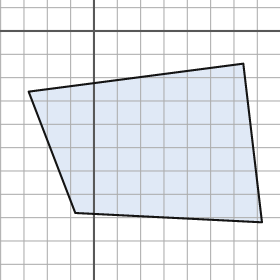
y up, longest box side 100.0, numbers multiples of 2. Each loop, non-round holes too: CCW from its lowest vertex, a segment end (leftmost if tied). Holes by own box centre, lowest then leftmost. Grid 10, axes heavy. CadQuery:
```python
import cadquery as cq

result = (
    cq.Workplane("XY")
    .moveTo(72.0, -82.0)
    .lineTo(64.0, -14.0)
    .lineTo(-28.0, -26.0)
    .lineTo(-8.0, -78.0)
    .close()
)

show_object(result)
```